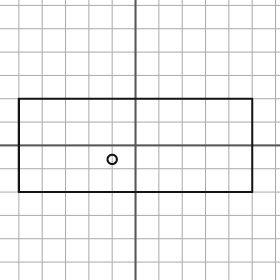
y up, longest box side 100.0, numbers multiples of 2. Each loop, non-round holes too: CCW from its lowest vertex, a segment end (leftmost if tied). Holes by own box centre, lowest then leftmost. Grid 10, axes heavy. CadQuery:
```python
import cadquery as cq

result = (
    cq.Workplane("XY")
    .moveTo(-50.0, -20.0)
    .lineTo(50.0, -20.0)
    .lineTo(50.0, 20.0)
    .lineTo(-50.0, 20.0)
    .close()
    .moveTo(-10.0, -6.0)
    .circle(2.0)
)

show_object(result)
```